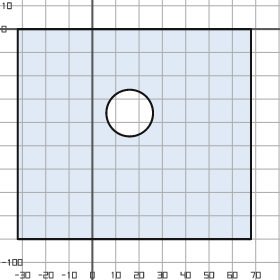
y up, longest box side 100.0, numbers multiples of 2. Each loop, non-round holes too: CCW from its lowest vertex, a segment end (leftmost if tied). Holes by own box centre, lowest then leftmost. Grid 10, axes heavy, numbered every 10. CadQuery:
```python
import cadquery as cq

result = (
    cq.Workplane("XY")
    .moveTo(-32.0, -90.0)
    .lineTo(68.0, -90.0)
    .lineTo(68.0, 0.0)
    .lineTo(-32.0, 0.0)
    .close()
    .moveTo(16.0, -36.0)
    .circle(10.0)
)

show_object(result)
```